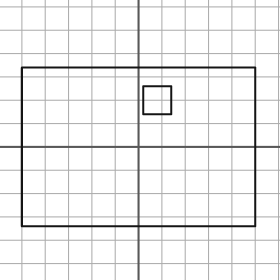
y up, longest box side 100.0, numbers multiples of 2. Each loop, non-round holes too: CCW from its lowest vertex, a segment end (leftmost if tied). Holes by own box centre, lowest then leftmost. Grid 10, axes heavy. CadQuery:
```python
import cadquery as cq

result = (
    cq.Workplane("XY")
    .moveTo(-50.0, -34.0)
    .lineTo(50.0, -34.0)
    .lineTo(50.0, 34.0)
    .lineTo(-50.0, 34.0)
    .close()
    .moveTo(2.0, 14.0)
    .lineTo(14.0, 14.0)
    .lineTo(14.0, 26.0)
    .lineTo(2.0, 26.0)
    .close()
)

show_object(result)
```